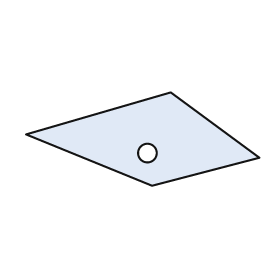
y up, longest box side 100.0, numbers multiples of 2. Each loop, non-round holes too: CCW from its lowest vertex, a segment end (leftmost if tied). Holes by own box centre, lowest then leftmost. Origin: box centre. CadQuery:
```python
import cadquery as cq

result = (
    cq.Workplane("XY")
    .moveTo(4.0, -20.0)
    .lineTo(50.0, -8.0)
    .lineTo(12.0, 20.0)
    .lineTo(-50.0, 2.0)
    .close()
    .moveTo(2.0, -6.0)
    .circle(4.0)
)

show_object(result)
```